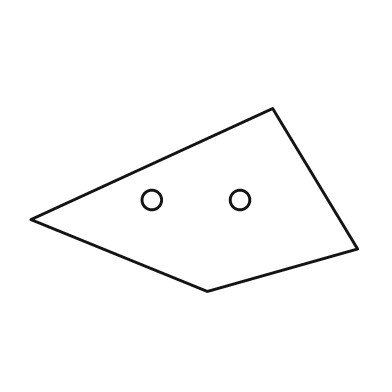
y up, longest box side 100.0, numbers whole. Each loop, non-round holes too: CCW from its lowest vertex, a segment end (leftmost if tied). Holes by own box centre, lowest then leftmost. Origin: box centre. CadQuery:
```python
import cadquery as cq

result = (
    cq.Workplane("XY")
    .moveTo(4.0, -28.0)
    .lineTo(50.0, -15.0)
    .lineTo(24.0, 28.0)
    .lineTo(-50.0, -6.0)
    .close()
    .moveTo(-13.0, 0.0)
    .circle(3.0)
    .moveTo(14.0, 0.0)
    .circle(3.0)
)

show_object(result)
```